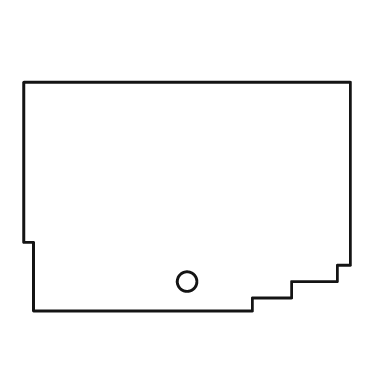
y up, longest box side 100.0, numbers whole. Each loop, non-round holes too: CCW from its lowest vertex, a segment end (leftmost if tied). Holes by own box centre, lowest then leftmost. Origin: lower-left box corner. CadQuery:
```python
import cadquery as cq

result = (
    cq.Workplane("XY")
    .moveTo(3.0, 0.0)
    .lineTo(70.0, 0.0)
    .lineTo(70.0, 4.0)
    .lineTo(82.0, 4.0)
    .lineTo(82.0, 9.0)
    .lineTo(96.0, 9.0)
    .lineTo(96.0, 14.0)
    .lineTo(100.0, 14.0)
    .lineTo(100.0, 70.0)
    .lineTo(0.0, 70.0)
    .lineTo(0.0, 21.0)
    .lineTo(3.0, 21.0)
    .close()
    .moveTo(50.0, 9.0)
    .circle(3.0)
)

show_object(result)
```